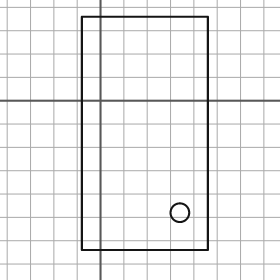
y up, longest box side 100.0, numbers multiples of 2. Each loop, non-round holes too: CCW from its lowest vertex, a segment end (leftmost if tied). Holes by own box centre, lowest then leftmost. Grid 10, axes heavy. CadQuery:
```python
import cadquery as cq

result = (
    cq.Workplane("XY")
    .moveTo(-8.0, -64.0)
    .lineTo(46.0, -64.0)
    .lineTo(46.0, 36.0)
    .lineTo(-8.0, 36.0)
    .close()
    .moveTo(34.0, -48.0)
    .circle(4.0)
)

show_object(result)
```